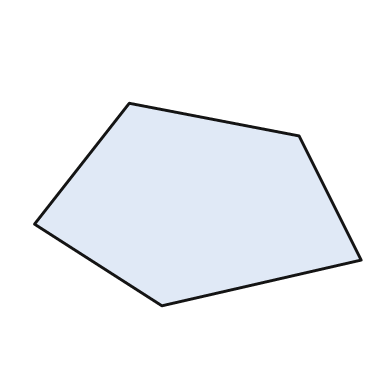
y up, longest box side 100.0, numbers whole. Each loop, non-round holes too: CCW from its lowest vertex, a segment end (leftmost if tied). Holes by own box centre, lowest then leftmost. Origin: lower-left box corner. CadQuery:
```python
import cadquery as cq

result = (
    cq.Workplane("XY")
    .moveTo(39.0, 0.0)
    .lineTo(100.0, 14.0)
    .lineTo(81.0, 52.0)
    .lineTo(29.0, 62.0)
    .lineTo(0.0, 25.0)
    .close()
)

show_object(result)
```